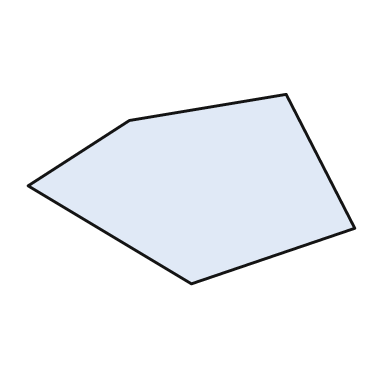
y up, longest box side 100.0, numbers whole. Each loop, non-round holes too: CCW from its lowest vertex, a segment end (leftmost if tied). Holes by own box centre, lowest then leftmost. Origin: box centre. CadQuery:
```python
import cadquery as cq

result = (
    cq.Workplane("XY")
    .moveTo(0.0, -29.0)
    .lineTo(50.0, -12.0)
    .lineTo(29.0, 29.0)
    .lineTo(-19.0, 21.0)
    .lineTo(-50.0, 1.0)
    .close()
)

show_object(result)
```